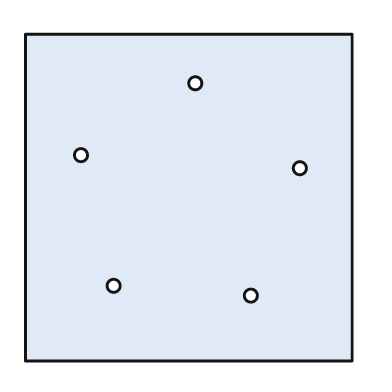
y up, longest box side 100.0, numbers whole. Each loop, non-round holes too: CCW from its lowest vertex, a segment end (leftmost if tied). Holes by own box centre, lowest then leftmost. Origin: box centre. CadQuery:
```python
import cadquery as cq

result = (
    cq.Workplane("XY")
    .moveTo(-50.0, -50.0)
    .lineTo(50.0, -50.0)
    .lineTo(50.0, 50.0)
    .lineTo(-50.0, 50.0)
    .close()
    .moveTo(19.0, -30.0)
    .circle(2.0)
    .moveTo(-23.0, -27.0)
    .circle(2.0)
    .moveTo(34.0, 9.0)
    .circle(2.0)
    .moveTo(-33.0, 13.0)
    .circle(2.0)
    .moveTo(2.0, 35.0)
    .circle(2.0)
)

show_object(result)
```